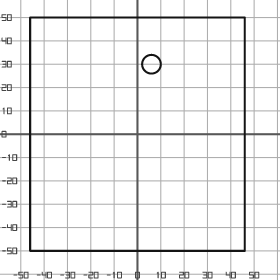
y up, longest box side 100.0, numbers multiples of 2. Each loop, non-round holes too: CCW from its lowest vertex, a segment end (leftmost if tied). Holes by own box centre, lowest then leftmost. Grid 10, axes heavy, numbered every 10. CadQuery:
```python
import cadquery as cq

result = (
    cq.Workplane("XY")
    .moveTo(-46.0, -50.0)
    .lineTo(46.0, -50.0)
    .lineTo(46.0, 50.0)
    .lineTo(-46.0, 50.0)
    .close()
    .moveTo(6.0, 30.0)
    .circle(4.0)
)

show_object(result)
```